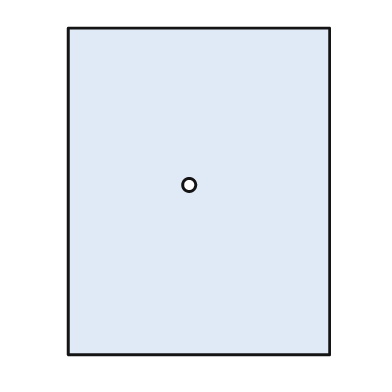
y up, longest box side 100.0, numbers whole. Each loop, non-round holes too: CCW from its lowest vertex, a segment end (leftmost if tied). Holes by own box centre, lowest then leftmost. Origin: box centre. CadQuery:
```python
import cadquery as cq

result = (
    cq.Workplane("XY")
    .moveTo(-40.0, -50.0)
    .lineTo(40.0, -50.0)
    .lineTo(40.0, 50.0)
    .lineTo(-40.0, 50.0)
    .close()
    .moveTo(-3.0, 2.0)
    .circle(2.0)
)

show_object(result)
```